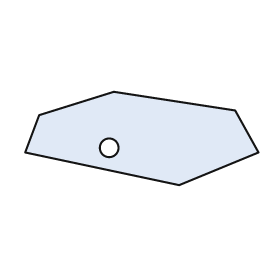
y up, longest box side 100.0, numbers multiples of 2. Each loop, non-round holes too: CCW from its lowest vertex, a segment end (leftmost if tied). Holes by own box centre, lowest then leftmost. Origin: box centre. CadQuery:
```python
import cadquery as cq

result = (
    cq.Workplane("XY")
    .moveTo(16.0, -20.0)
    .lineTo(50.0, -6.0)
    .lineTo(40.0, 12.0)
    .lineTo(-12.0, 20.0)
    .lineTo(-44.0, 10.0)
    .lineTo(-50.0, -6.0)
    .close()
    .moveTo(-14.0, -4.0)
    .circle(4.0)
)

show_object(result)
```